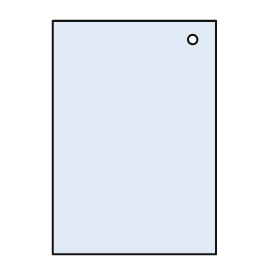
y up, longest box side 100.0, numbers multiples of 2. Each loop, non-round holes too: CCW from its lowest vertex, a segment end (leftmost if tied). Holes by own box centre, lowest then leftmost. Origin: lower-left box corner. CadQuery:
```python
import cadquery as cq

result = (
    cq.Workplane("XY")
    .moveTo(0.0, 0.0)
    .lineTo(70.0, 0.0)
    .lineTo(70.0, 100.0)
    .lineTo(0.0, 100.0)
    .close()
    .moveTo(60.0, 92.0)
    .circle(2.0)
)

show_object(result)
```